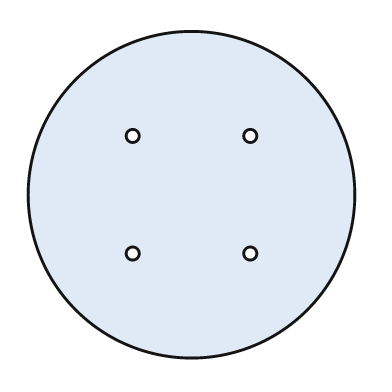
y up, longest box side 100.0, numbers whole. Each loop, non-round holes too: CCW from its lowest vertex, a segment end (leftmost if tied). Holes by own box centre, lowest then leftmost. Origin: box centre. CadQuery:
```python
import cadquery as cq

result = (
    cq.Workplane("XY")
    .moveTo(0.0, 0.0)
    .circle(50.0)
    .moveTo(-18.0, -18.0)
    .circle(2.0)
    .moveTo(18.0, -18.0)
    .circle(2.0)
    .moveTo(-18.0, 18.0)
    .circle(2.0)
    .moveTo(18.0, 18.0)
    .circle(2.0)
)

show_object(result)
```